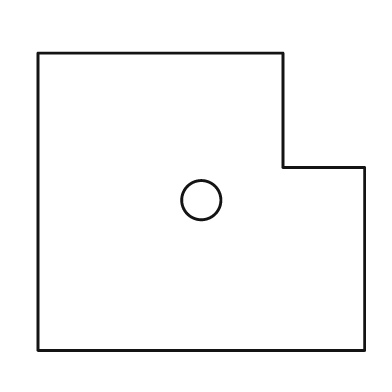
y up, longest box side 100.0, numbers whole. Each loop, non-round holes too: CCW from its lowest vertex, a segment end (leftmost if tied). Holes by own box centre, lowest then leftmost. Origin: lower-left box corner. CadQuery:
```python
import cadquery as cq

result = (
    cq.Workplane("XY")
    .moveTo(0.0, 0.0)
    .lineTo(100.0, 0.0)
    .lineTo(100.0, 56.0)
    .lineTo(75.0, 56.0)
    .lineTo(75.0, 91.0)
    .lineTo(0.0, 91.0)
    .close()
    .moveTo(50.0, 46.0)
    .circle(6.0)
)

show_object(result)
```